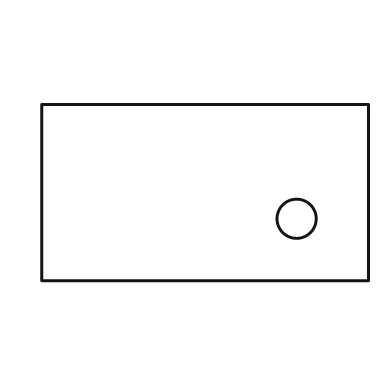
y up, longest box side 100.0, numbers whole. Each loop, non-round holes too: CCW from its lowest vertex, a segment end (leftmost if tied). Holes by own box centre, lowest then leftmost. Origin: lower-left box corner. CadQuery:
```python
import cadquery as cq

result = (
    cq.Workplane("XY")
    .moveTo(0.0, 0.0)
    .lineTo(100.0, 0.0)
    .lineTo(100.0, 54.0)
    .lineTo(0.0, 54.0)
    .close()
    .moveTo(78.0, 19.0)
    .circle(6.0)
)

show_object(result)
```